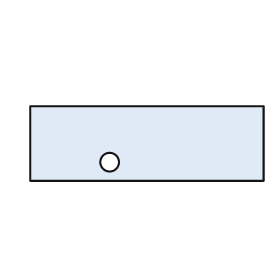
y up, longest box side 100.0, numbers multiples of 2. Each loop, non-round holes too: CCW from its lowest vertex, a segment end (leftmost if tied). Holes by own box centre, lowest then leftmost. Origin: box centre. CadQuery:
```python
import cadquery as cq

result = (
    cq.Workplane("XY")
    .moveTo(-50.0, -16.0)
    .lineTo(50.0, -16.0)
    .lineTo(50.0, 16.0)
    .lineTo(-50.0, 16.0)
    .close()
    .moveTo(-16.0, -8.0)
    .circle(4.0)
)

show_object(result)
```